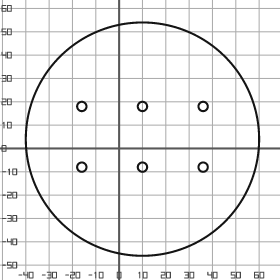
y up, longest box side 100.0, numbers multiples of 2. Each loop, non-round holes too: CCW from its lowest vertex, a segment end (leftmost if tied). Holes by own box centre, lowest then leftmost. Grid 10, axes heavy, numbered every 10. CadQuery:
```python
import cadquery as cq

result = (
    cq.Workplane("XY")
    .moveTo(10.0, 4.0)
    .circle(50.0)
    .moveTo(-16.0, -8.0)
    .circle(2.0)
    .moveTo(10.0, -8.0)
    .circle(2.0)
    .moveTo(36.0, -8.0)
    .circle(2.0)
    .moveTo(-16.0, 18.0)
    .circle(2.0)
    .moveTo(10.0, 18.0)
    .circle(2.0)
    .moveTo(36.0, 18.0)
    .circle(2.0)
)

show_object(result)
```